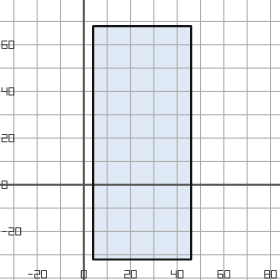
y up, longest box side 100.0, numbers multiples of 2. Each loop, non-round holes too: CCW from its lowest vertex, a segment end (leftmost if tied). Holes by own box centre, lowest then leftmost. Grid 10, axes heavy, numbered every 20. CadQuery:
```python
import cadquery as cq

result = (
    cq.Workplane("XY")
    .moveTo(4.0, -32.0)
    .lineTo(46.0, -32.0)
    .lineTo(46.0, 68.0)
    .lineTo(4.0, 68.0)
    .close()
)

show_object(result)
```